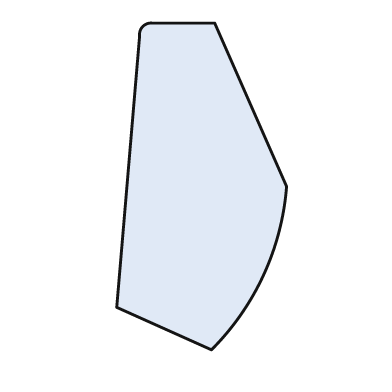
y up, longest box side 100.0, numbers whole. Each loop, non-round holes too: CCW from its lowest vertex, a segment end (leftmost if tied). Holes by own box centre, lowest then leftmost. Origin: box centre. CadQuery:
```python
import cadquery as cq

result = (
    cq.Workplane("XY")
    .moveTo(3.0, -50.0)
    .threePointArc((19.0, -27.0), (26.0, 0.0))
    .lineTo(4.0, 50.0)
    .lineTo(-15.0, 50.0)
    .threePointArc((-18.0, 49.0), (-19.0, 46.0))
    .lineTo(-26.0, -37.0)
    .close()
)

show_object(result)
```